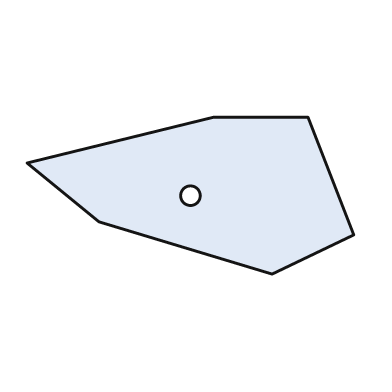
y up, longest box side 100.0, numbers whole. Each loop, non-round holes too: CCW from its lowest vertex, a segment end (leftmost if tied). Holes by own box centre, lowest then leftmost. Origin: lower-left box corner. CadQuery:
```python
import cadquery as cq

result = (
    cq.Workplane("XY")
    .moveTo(75.0, 0.0)
    .lineTo(100.0, 12.0)
    .lineTo(86.0, 48.0)
    .lineTo(57.0, 48.0)
    .lineTo(0.0, 34.0)
    .lineTo(22.0, 16.0)
    .close()
    .moveTo(50.0, 24.0)
    .circle(3.0)
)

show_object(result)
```